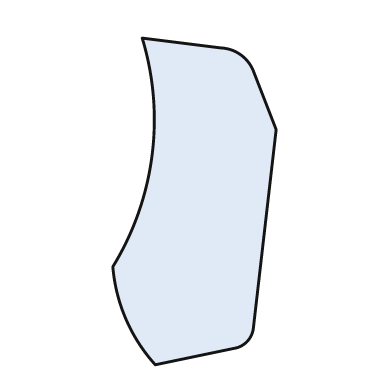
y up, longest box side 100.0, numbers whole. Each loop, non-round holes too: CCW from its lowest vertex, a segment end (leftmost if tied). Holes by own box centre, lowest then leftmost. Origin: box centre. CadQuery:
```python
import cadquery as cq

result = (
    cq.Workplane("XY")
    .moveTo(-12.0, -50.0)
    .lineTo(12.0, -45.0)
    .threePointArc((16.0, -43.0), (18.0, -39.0))
    .lineTo(25.0, 22.0)
    .lineTo(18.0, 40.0)
    .threePointArc((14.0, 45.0), (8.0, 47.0))
    .lineTo(-16.0, 50.0)
    .threePointArc((-13.0, 14.0), (-25.0, -20.0))
    .threePointArc((-21.0, -36.0), (-12.0, -50.0))
    .close()
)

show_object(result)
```